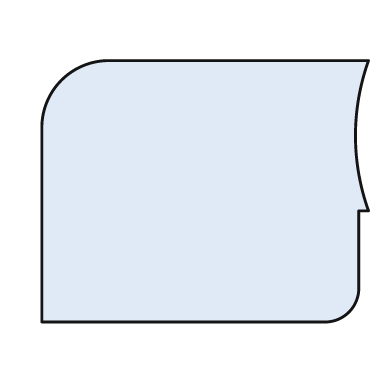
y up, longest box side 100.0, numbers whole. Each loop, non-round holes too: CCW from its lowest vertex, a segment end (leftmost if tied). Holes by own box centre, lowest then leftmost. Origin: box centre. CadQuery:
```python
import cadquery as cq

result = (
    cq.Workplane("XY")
    .moveTo(-50.0, -40.0)
    .lineTo(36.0, -40.0)
    .threePointArc((44.0, -37.0), (47.0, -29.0))
    .lineTo(47.0, -6.0)
    .lineTo(50.0, -6.0)
    .threePointArc((46.0, 17.0), (50.0, 40.0))
    .lineTo(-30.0, 40.0)
    .threePointArc((-44.0, 34.0), (-50.0, 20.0))
    .close()
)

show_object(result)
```